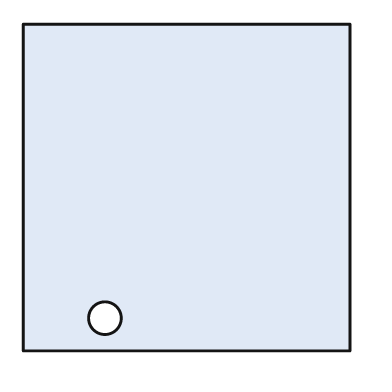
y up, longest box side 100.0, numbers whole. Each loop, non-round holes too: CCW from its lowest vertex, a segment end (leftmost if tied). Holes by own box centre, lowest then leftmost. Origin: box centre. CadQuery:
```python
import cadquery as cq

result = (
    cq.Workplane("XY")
    .moveTo(-50.0, -50.0)
    .lineTo(50.0, -50.0)
    .lineTo(50.0, 50.0)
    .lineTo(-50.0, 50.0)
    .close()
    .moveTo(-25.0, -40.0)
    .circle(5.0)
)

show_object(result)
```